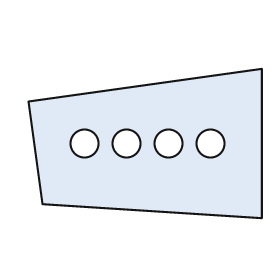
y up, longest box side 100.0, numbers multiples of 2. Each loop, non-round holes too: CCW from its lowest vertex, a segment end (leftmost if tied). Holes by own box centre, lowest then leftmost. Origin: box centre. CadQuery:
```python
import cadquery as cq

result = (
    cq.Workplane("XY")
    .moveTo(50.0, -32.0)
    .lineTo(50.0, 32.0)
    .lineTo(-50.0, 18.0)
    .lineTo(-44.0, -26.0)
    .close()
    .moveTo(-26.0, 0.0)
    .circle(6.0)
    .moveTo(-8.0, 0.0)
    .circle(6.0)
    .moveTo(10.0, 0.0)
    .circle(6.0)
    .moveTo(28.0, 0.0)
    .circle(6.0)
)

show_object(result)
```